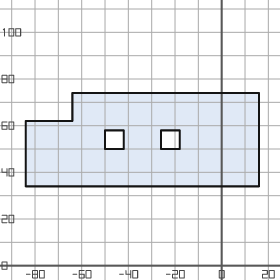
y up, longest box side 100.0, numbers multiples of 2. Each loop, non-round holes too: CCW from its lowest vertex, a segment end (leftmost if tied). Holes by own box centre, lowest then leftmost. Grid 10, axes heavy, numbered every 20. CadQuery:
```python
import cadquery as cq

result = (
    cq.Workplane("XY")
    .moveTo(-84.0, 34.0)
    .lineTo(16.0, 34.0)
    .lineTo(16.0, 74.0)
    .lineTo(-64.0, 74.0)
    .lineTo(-64.0, 62.0)
    .lineTo(-84.0, 62.0)
    .close()
    .moveTo(-50.0, 50.0)
    .lineTo(-42.0, 50.0)
    .lineTo(-42.0, 58.0)
    .lineTo(-50.0, 58.0)
    .close()
    .moveTo(-26.0, 50.0)
    .lineTo(-18.0, 50.0)
    .lineTo(-18.0, 58.0)
    .lineTo(-26.0, 58.0)
    .close()
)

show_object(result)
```